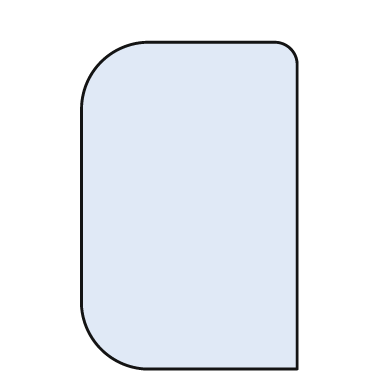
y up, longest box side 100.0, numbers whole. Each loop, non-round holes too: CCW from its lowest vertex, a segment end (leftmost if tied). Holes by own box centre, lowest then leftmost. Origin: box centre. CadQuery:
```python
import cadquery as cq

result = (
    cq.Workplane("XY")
    .moveTo(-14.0, -50.0)
    .lineTo(33.0, -50.0)
    .lineTo(33.0, 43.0)
    .threePointArc((31.0, 48.0), (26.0, 50.0))
    .lineTo(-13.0, 50.0)
    .threePointArc((-27.0, 44.0), (-33.0, 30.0))
    .lineTo(-33.0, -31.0)
    .threePointArc((-27.0, -44.0), (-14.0, -50.0))
    .close()
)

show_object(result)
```